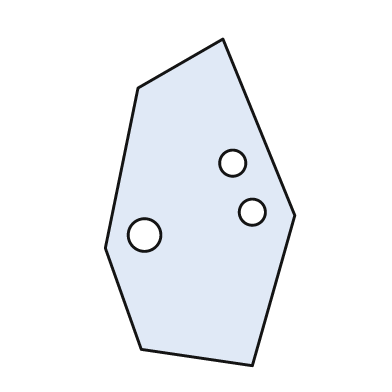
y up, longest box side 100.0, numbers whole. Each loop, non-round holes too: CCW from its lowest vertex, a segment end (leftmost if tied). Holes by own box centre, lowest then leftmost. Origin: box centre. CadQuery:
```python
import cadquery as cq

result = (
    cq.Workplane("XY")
    .moveTo(16.0, -50.0)
    .lineTo(29.0, -4.0)
    .lineTo(7.0, 50.0)
    .lineTo(-19.0, 35.0)
    .lineTo(-29.0, -14.0)
    .lineTo(-18.0, -45.0)
    .close()
    .moveTo(-17.0, -10.0)
    .circle(5.0)
    .moveTo(16.0, -3.0)
    .circle(4.0)
    .moveTo(10.0, 12.0)
    .circle(4.0)
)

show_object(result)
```